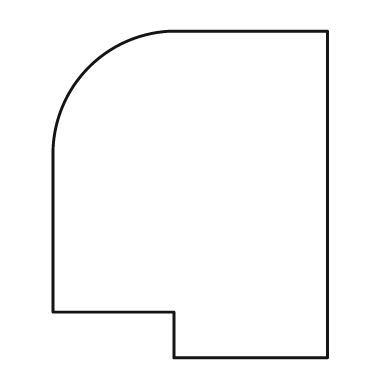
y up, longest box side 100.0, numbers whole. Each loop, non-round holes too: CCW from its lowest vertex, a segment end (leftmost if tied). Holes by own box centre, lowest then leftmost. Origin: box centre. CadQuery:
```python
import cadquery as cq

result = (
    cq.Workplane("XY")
    .moveTo(-5.0, -50.0)
    .lineTo(42.0, -50.0)
    .lineTo(42.0, 50.0)
    .lineTo(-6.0, 50.0)
    .threePointArc((-31.0, 39.0), (-42.0, 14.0))
    .lineTo(-42.0, -36.0)
    .lineTo(-5.0, -36.0)
    .close()
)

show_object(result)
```